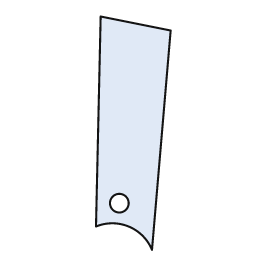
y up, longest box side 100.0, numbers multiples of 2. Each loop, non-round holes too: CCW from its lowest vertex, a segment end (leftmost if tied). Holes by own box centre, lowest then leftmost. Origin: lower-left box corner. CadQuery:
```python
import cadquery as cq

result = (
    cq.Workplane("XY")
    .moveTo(24.0, 0.0)
    .lineTo(32.0, 94.0)
    .lineTo(2.0, 100.0)
    .lineTo(0.0, 10.0)
    .threePointArc((14.0, 10.0), (24.0, 0.0))
    .close()
    .moveTo(10.0, 20.0)
    .circle(4.0)
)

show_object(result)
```